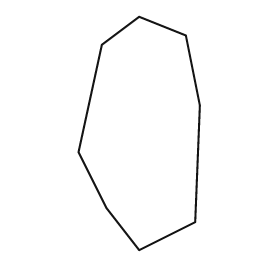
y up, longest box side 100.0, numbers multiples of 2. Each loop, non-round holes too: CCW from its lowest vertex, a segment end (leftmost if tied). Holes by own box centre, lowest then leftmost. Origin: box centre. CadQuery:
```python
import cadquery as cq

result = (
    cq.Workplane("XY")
    .moveTo(0.0, -50.0)
    .lineTo(24.0, -38.0)
    .lineTo(26.0, 12.0)
    .lineTo(20.0, 42.0)
    .lineTo(0.0, 50.0)
    .lineTo(-16.0, 38.0)
    .lineTo(-26.0, -8.0)
    .lineTo(-14.0, -32.0)
    .close()
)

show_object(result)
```